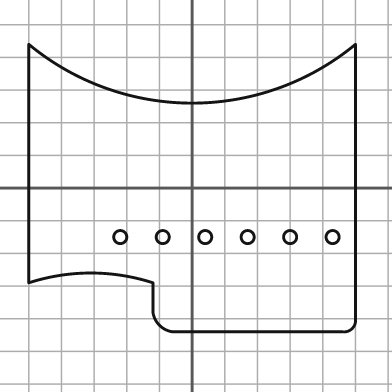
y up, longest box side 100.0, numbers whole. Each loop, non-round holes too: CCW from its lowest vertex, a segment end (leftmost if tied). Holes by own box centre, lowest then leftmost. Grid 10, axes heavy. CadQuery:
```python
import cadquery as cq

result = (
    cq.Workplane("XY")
    .moveTo(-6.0, -44.0)
    .lineTo(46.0, -44.0)
    .threePointArc((49.0, -43.0), (50.0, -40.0))
    .lineTo(50.0, 44.0)
    .threePointArc((0.0, 26.0), (-50.0, 44.0))
    .lineTo(-50.0, -29.0)
    .threePointArc((-31.0, -26.0), (-12.0, -29.0))
    .lineTo(-12.0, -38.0)
    .threePointArc((-10.0, -42.0), (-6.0, -44.0))
    .close()
    .moveTo(-22.0, -15.0)
    .circle(2.0)
    .moveTo(-9.0, -15.0)
    .circle(2.0)
    .moveTo(4.0, -15.0)
    .circle(2.0)
    .moveTo(17.0, -15.0)
    .circle(2.0)
    .moveTo(30.0, -15.0)
    .circle(2.0)
    .moveTo(43.0, -15.0)
    .circle(2.0)
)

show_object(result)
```